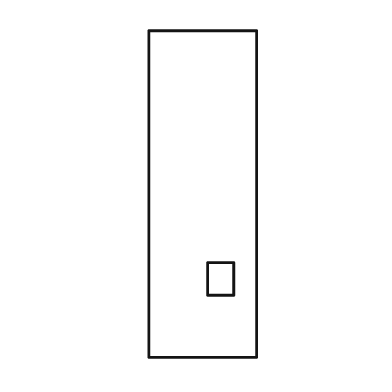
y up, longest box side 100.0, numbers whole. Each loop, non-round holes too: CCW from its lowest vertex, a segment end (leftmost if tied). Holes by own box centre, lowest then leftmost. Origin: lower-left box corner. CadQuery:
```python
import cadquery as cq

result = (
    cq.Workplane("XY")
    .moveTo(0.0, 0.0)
    .lineTo(33.0, 0.0)
    .lineTo(33.0, 100.0)
    .lineTo(0.0, 100.0)
    .close()
    .moveTo(18.0, 19.0)
    .lineTo(26.0, 19.0)
    .lineTo(26.0, 29.0)
    .lineTo(18.0, 29.0)
    .close()
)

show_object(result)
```